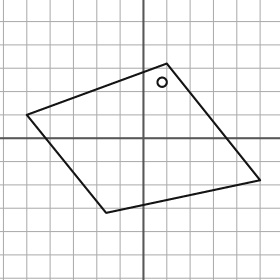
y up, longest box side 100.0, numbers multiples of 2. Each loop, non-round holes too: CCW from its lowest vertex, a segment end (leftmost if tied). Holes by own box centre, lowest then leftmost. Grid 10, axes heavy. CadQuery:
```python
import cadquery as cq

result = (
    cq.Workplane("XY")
    .moveTo(-16.0, -32.0)
    .lineTo(50.0, -18.0)
    .lineTo(10.0, 32.0)
    .lineTo(-50.0, 10.0)
    .close()
    .moveTo(8.0, 24.0)
    .circle(2.0)
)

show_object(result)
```